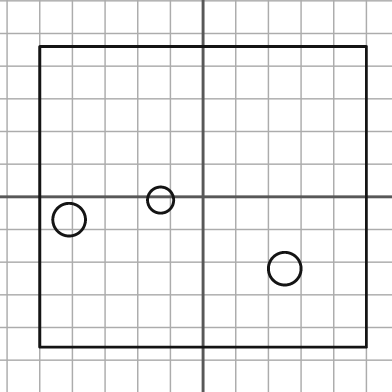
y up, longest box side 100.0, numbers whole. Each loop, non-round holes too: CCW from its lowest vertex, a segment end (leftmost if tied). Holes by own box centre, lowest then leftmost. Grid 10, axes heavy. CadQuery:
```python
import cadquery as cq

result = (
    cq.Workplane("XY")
    .moveTo(-50.0, -46.0)
    .lineTo(50.0, -46.0)
    .lineTo(50.0, 46.0)
    .lineTo(-50.0, 46.0)
    .close()
    .moveTo(25.0, -22.0)
    .circle(5.0)
    .moveTo(-41.0, -7.0)
    .circle(5.0)
    .moveTo(-13.0, -1.0)
    .circle(4.0)
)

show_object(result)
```